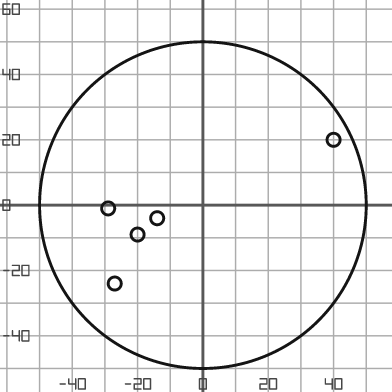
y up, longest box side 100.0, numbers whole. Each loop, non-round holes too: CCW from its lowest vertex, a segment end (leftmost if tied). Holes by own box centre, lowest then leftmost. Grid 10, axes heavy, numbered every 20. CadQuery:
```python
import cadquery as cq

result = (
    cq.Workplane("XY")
    .moveTo(0.0, 0.0)
    .circle(50.0)
    .moveTo(-27.0, -24.0)
    .circle(2.0)
    .moveTo(-20.0, -9.0)
    .circle(2.0)
    .moveTo(-14.0, -4.0)
    .circle(2.0)
    .moveTo(-29.0, -1.0)
    .circle(2.0)
    .moveTo(40.0, 20.0)
    .circle(2.0)
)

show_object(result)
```